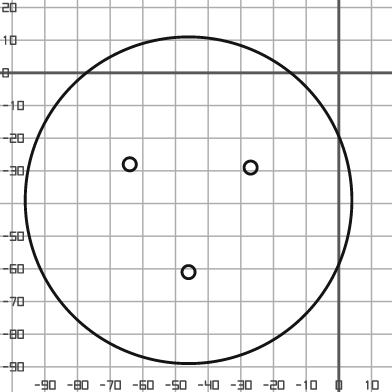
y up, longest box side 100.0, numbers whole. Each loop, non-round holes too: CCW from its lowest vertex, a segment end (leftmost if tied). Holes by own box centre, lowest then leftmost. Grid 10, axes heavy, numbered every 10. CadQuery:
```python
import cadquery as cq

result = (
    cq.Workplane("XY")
    .moveTo(-46.0, -39.0)
    .circle(50.0)
    .moveTo(-46.0, -61.0)
    .circle(2.0)
    .moveTo(-27.0, -29.0)
    .circle(2.0)
    .moveTo(-64.0, -28.0)
    .circle(2.0)
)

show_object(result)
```